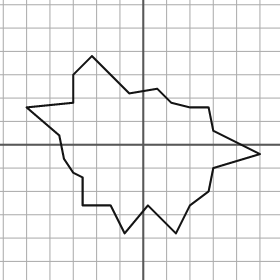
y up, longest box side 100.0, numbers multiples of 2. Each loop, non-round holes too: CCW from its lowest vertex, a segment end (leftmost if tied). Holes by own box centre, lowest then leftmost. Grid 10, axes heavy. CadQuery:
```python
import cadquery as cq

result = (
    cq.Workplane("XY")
    .moveTo(-8.0, -38.0)
    .lineTo(2.0, -26.0)
    .lineTo(14.0, -38.0)
    .lineTo(20.0, -26.0)
    .lineTo(28.0, -20.0)
    .lineTo(30.0, -10.0)
    .lineTo(50.0, -4.0)
    .lineTo(30.0, 6.0)
    .lineTo(28.0, 16.0)
    .lineTo(20.0, 16.0)
    .lineTo(12.0, 18.0)
    .lineTo(6.0, 24.0)
    .lineTo(-6.0, 22.0)
    .lineTo(-22.0, 38.0)
    .lineTo(-30.0, 30.0)
    .lineTo(-30.0, 18.0)
    .lineTo(-50.0, 16.0)
    .lineTo(-36.0, 4.0)
    .lineTo(-34.0, -6.0)
    .lineTo(-30.0, -12.0)
    .lineTo(-26.0, -14.0)
    .lineTo(-26.0, -26.0)
    .lineTo(-14.0, -26.0)
    .close()
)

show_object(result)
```